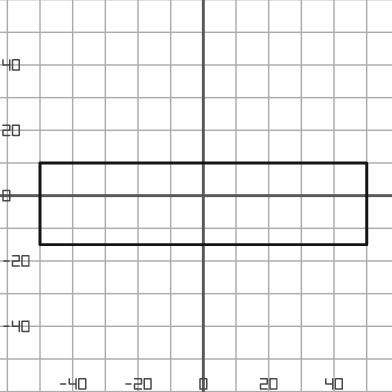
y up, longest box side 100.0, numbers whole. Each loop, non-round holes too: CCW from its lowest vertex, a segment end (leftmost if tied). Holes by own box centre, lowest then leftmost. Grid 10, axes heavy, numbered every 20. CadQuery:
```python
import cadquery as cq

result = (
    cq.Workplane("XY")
    .moveTo(-50.0, -15.0)
    .lineTo(50.0, -15.0)
    .lineTo(50.0, 10.0)
    .lineTo(-50.0, 10.0)
    .close()
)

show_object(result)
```